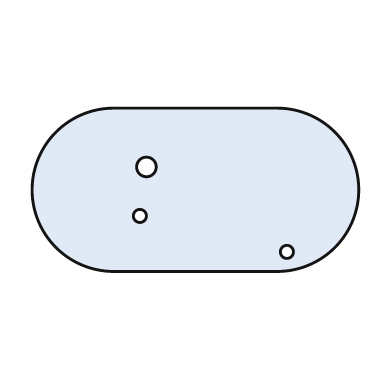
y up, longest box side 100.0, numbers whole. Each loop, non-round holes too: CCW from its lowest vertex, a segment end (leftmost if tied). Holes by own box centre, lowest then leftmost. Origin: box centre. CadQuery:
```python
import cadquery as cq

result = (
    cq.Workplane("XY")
    .moveTo(-25.0, -25.0)
    .lineTo(25.0, -25.0)
    .threePointArc((50.0, 0.0), (25.0, 25.0))
    .lineTo(-25.0, 25.0)
    .threePointArc((-50.0, 0.0), (-25.0, -25.0))
    .close()
    .moveTo(28.0, -19.0)
    .circle(2.0)
    .moveTo(-17.0, -8.0)
    .circle(2.0)
    .moveTo(-15.0, 7.0)
    .circle(3.0)
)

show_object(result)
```